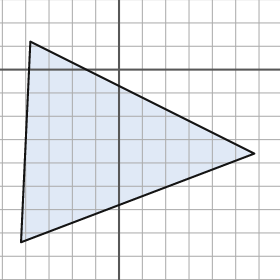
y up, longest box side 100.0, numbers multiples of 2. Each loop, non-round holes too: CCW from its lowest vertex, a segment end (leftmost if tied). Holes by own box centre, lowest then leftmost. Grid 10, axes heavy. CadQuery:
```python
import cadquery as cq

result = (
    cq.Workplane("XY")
    .moveTo(-42.0, -74.0)
    .lineTo(58.0, -36.0)
    .lineTo(-38.0, 12.0)
    .close()
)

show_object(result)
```